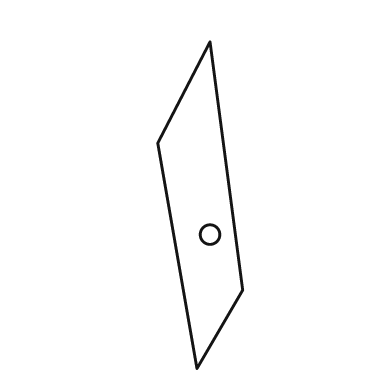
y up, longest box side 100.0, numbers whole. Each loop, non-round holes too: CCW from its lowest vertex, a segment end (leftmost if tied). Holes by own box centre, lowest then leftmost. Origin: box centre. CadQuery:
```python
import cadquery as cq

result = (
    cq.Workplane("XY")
    .moveTo(-1.0, -50.0)
    .lineTo(13.0, -26.0)
    .lineTo(3.0, 50.0)
    .lineTo(-13.0, 19.0)
    .close()
    .moveTo(3.0, -9.0)
    .circle(3.0)
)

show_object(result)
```